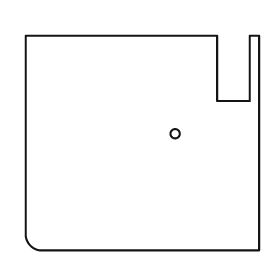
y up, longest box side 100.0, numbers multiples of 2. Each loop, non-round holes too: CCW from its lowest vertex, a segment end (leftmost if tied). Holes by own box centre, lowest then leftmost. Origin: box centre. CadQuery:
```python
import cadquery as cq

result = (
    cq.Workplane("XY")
    .moveTo(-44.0, -46.0)
    .lineTo(50.0, -46.0)
    .lineTo(50.0, 46.0)
    .lineTo(46.0, 46.0)
    .lineTo(46.0, 18.0)
    .lineTo(32.0, 18.0)
    .lineTo(32.0, 46.0)
    .lineTo(-50.0, 46.0)
    .lineTo(-50.0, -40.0)
    .threePointArc((-48.0, -44.0), (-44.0, -46.0))
    .close()
    .moveTo(14.0, 4.0)
    .circle(2.0)
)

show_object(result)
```